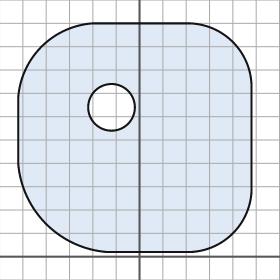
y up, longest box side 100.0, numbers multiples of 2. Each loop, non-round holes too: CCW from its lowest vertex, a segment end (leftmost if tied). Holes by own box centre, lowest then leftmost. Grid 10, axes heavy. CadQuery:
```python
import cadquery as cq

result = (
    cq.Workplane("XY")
    .moveTo(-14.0, 2.0)
    .lineTo(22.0, 2.0)
    .threePointArc((40.0, 10.0), (48.0, 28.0))
    .lineTo(48.0, 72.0)
    .threePointArc((40.0, 92.0), (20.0, 100.0))
    .lineTo(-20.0, 100.0)
    .threePointArc((-42.0, 90.0), (-52.0, 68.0))
    .lineTo(-52.0, 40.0)
    .threePointArc((-40.0, 14.0), (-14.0, 2.0))
    .close()
    .moveTo(-12.0, 64.0)
    .circle(10.0)
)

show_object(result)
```